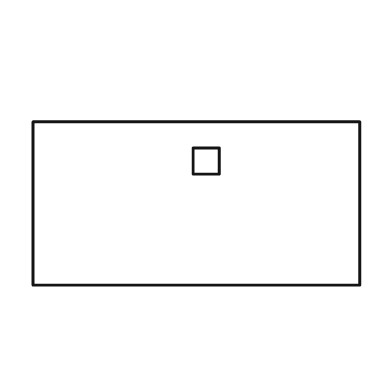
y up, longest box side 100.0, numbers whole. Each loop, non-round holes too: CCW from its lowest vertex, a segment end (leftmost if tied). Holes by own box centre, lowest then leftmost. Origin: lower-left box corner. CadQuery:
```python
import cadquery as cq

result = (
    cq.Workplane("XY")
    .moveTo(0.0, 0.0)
    .lineTo(100.0, 0.0)
    .lineTo(100.0, 50.0)
    .lineTo(0.0, 50.0)
    .close()
    .moveTo(49.0, 34.0)
    .lineTo(57.0, 34.0)
    .lineTo(57.0, 42.0)
    .lineTo(49.0, 42.0)
    .close()
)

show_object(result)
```